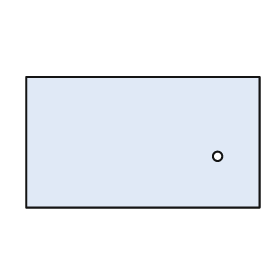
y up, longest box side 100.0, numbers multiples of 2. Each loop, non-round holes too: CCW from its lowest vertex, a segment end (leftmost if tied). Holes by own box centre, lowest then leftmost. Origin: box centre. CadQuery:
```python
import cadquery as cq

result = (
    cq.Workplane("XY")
    .moveTo(-50.0, -28.0)
    .lineTo(50.0, -28.0)
    .lineTo(50.0, 28.0)
    .lineTo(-50.0, 28.0)
    .close()
    .moveTo(32.0, -6.0)
    .circle(2.0)
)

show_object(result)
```